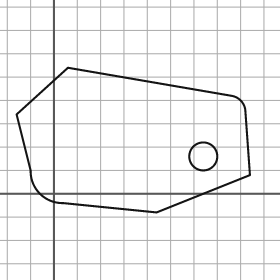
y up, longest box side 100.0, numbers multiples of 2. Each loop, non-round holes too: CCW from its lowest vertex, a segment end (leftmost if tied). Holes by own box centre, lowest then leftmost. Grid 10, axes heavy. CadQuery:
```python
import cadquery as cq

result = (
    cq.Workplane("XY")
    .moveTo(44.0, -8.0)
    .lineTo(84.0, 8.0)
    .lineTo(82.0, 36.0)
    .threePointArc((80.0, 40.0), (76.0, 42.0))
    .lineTo(6.0, 54.0)
    .lineTo(-16.0, 34.0)
    .lineTo(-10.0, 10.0)
    .threePointArc((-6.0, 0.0), (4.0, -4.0))
    .close()
    .moveTo(64.0, 16.0)
    .circle(6.0)
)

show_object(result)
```